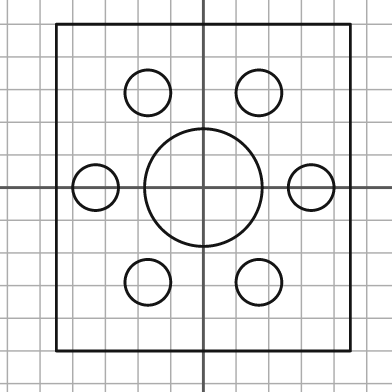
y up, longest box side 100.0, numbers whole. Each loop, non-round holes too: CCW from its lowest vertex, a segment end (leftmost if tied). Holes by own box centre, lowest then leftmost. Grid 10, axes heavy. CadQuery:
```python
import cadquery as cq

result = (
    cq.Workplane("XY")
    .moveTo(-45.0, -50.0)
    .lineTo(45.0, -50.0)
    .lineTo(45.0, 50.0)
    .lineTo(-45.0, 50.0)
    .close()
    .moveTo(-17.0, -29.0)
    .circle(7.0)
    .moveTo(17.0, -29.0)
    .circle(7.0)
    .moveTo(-33.0, 0.0)
    .circle(7.0)
    .moveTo(0.0, 0.0)
    .circle(18.0)
    .moveTo(33.0, 0.0)
    .circle(7.0)
    .moveTo(-17.0, 29.0)
    .circle(7.0)
    .moveTo(17.0, 29.0)
    .circle(7.0)
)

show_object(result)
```